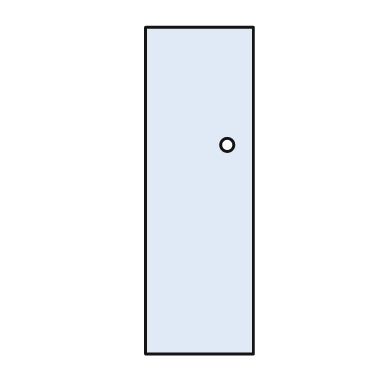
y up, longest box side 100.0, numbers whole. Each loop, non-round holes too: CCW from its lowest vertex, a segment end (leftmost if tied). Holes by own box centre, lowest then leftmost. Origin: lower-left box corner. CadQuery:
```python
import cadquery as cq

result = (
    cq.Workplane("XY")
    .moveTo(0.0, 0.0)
    .lineTo(33.0, 0.0)
    .lineTo(33.0, 100.0)
    .lineTo(0.0, 100.0)
    .close()
    .moveTo(25.0, 64.0)
    .circle(2.0)
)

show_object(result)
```